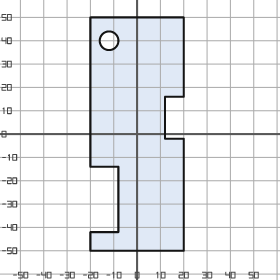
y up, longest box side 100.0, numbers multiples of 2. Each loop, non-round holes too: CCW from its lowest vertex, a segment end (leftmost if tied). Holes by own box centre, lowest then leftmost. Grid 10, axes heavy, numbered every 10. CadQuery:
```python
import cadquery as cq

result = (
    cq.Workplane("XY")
    .moveTo(-20.0, -50.0)
    .lineTo(20.0, -50.0)
    .lineTo(20.0, -2.0)
    .lineTo(12.0, -2.0)
    .lineTo(12.0, 16.0)
    .lineTo(20.0, 16.0)
    .lineTo(20.0, 50.0)
    .lineTo(-20.0, 50.0)
    .lineTo(-20.0, -14.0)
    .lineTo(-8.0, -14.0)
    .lineTo(-8.0, -42.0)
    .lineTo(-20.0, -42.0)
    .close()
    .moveTo(-12.0, 40.0)
    .circle(4.0)
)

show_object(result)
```